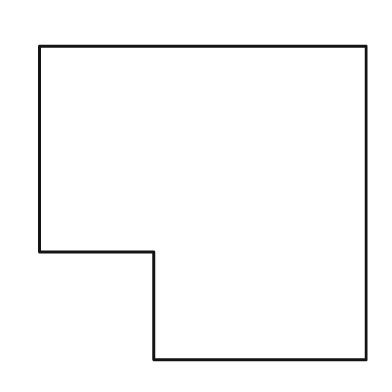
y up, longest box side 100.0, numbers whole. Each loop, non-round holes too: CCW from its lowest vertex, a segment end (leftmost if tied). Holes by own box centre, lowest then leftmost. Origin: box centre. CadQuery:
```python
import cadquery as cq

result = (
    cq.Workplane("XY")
    .moveTo(-15.0, -48.0)
    .lineTo(50.0, -48.0)
    .lineTo(50.0, 48.0)
    .lineTo(-50.0, 48.0)
    .lineTo(-50.0, -15.0)
    .lineTo(-15.0, -15.0)
    .close()
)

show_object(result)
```